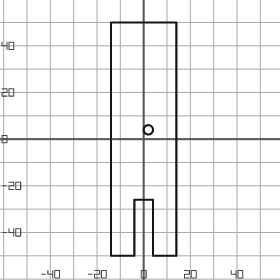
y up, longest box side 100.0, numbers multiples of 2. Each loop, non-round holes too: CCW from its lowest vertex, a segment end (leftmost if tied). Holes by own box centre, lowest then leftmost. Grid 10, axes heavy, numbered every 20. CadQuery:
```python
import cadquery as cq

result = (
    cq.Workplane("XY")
    .moveTo(-14.0, -50.0)
    .lineTo(-4.0, -50.0)
    .lineTo(-4.0, -26.0)
    .lineTo(4.0, -26.0)
    .lineTo(4.0, -50.0)
    .lineTo(14.0, -50.0)
    .lineTo(14.0, 50.0)
    .lineTo(-14.0, 50.0)
    .close()
    .moveTo(2.0, 4.0)
    .circle(2.0)
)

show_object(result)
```